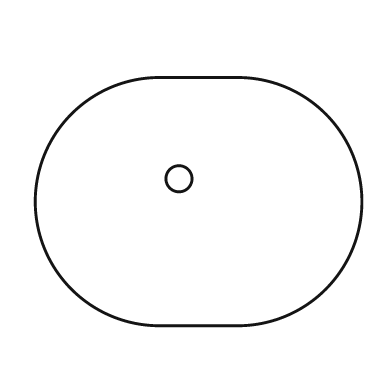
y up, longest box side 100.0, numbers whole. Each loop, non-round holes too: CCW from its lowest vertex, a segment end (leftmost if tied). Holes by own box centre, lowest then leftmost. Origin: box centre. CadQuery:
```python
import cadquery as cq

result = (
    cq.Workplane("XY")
    .moveTo(-12.0, -38.0)
    .lineTo(12.0, -38.0)
    .threePointArc((50.0, 0.0), (12.0, 38.0))
    .lineTo(-12.0, 38.0)
    .threePointArc((-50.0, 0.0), (-12.0, -38.0))
    .close()
    .moveTo(-6.0, 7.0)
    .circle(4.0)
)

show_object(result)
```